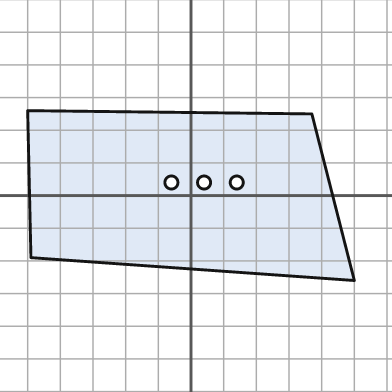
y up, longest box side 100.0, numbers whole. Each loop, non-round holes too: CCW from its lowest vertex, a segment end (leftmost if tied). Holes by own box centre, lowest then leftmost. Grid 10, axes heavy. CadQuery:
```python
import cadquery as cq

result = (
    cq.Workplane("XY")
    .moveTo(50.0, -26.0)
    .lineTo(37.0, 25.0)
    .lineTo(-50.0, 26.0)
    .lineTo(-49.0, -19.0)
    .close()
    .moveTo(-6.0, 4.0)
    .circle(2.0)
    .moveTo(4.0, 4.0)
    .circle(2.0)
    .moveTo(14.0, 4.0)
    .circle(2.0)
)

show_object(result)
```